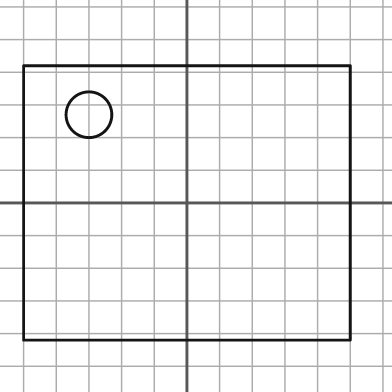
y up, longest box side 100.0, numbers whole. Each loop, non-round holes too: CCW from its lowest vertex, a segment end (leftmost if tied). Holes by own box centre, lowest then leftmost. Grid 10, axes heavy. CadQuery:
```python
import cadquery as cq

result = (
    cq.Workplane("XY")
    .moveTo(-50.0, -42.0)
    .lineTo(50.0, -42.0)
    .lineTo(50.0, 42.0)
    .lineTo(-50.0, 42.0)
    .close()
    .moveTo(-30.0, 27.0)
    .circle(7.0)
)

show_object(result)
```